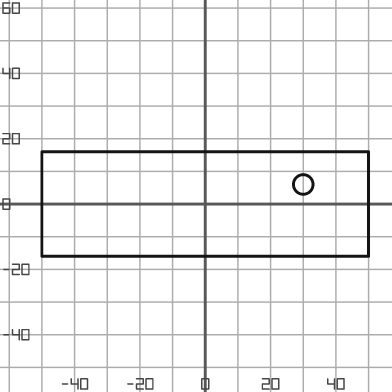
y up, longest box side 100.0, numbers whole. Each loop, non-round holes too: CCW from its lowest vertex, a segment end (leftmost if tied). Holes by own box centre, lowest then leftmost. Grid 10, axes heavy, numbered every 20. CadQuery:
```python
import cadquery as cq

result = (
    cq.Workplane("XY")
    .moveTo(-50.0, -16.0)
    .lineTo(50.0, -16.0)
    .lineTo(50.0, 16.0)
    .lineTo(-50.0, 16.0)
    .close()
    .moveTo(30.0, 6.0)
    .circle(3.0)
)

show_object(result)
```